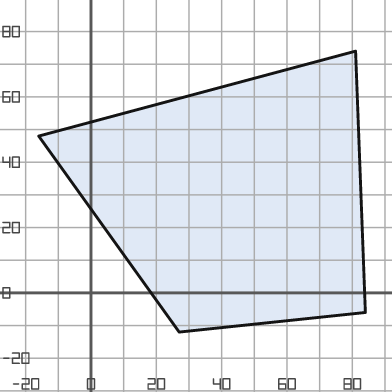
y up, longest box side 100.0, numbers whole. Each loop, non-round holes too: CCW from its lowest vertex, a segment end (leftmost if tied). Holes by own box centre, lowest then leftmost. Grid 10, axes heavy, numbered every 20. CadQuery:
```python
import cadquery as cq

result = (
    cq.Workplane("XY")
    .moveTo(27.0, -12.0)
    .lineTo(84.0, -6.0)
    .lineTo(81.0, 74.0)
    .lineTo(-16.0, 48.0)
    .close()
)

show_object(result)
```